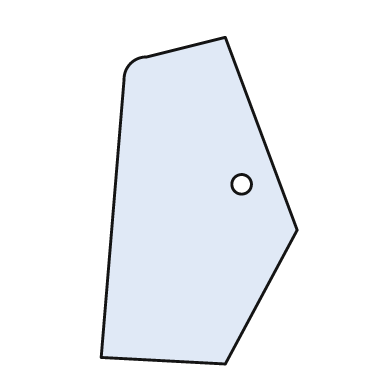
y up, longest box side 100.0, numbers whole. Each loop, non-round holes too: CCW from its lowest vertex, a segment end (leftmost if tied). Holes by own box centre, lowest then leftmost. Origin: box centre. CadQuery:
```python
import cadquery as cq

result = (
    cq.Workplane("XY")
    .moveTo(8.0, -50.0)
    .lineTo(30.0, -9.0)
    .lineTo(8.0, 50.0)
    .lineTo(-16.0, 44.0)
    .threePointArc((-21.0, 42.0), (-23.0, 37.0))
    .lineTo(-30.0, -48.0)
    .close()
    .moveTo(13.0, 5.0)
    .circle(3.0)
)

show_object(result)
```